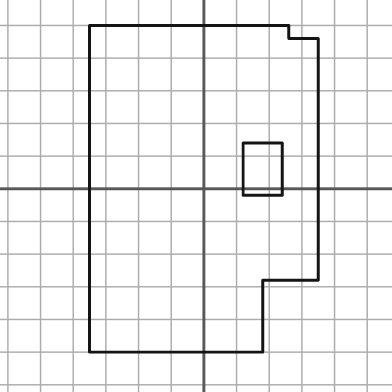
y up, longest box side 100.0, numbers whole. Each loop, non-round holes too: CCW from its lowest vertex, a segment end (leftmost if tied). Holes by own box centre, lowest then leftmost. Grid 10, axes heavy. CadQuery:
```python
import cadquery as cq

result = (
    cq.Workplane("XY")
    .moveTo(-35.0, -50.0)
    .lineTo(18.0, -50.0)
    .lineTo(18.0, -28.0)
    .lineTo(35.0, -28.0)
    .lineTo(35.0, 46.0)
    .lineTo(26.0, 46.0)
    .lineTo(26.0, 50.0)
    .lineTo(-35.0, 50.0)
    .close()
    .moveTo(12.0, -2.0)
    .lineTo(24.0, -2.0)
    .lineTo(24.0, 14.0)
    .lineTo(12.0, 14.0)
    .close()
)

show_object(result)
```